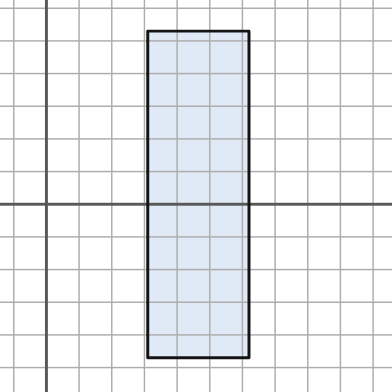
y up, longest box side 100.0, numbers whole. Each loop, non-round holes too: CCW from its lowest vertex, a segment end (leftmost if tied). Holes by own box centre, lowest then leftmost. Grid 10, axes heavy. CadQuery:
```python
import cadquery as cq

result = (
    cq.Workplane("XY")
    .moveTo(31.0, -47.0)
    .lineTo(62.0, -47.0)
    .lineTo(62.0, 53.0)
    .lineTo(31.0, 53.0)
    .close()
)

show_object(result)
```